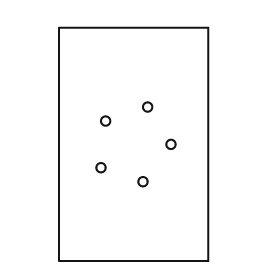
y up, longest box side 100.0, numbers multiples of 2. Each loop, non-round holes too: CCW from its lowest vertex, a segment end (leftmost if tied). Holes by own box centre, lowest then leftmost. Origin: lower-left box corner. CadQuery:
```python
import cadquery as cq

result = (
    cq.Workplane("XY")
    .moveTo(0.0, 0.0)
    .lineTo(64.0, 0.0)
    .lineTo(64.0, 100.0)
    .lineTo(0.0, 100.0)
    .close()
    .moveTo(36.0, 34.0)
    .circle(2.0)
    .moveTo(18.0, 40.0)
    .circle(2.0)
    .moveTo(48.0, 50.0)
    .circle(2.0)
    .moveTo(20.0, 60.0)
    .circle(2.0)
    .moveTo(38.0, 66.0)
    .circle(2.0)
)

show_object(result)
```